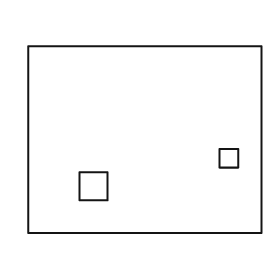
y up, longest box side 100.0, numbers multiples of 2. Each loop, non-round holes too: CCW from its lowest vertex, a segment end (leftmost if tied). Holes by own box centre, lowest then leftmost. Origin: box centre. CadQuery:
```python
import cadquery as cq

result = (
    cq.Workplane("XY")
    .moveTo(-50.0, -40.0)
    .lineTo(50.0, -40.0)
    .lineTo(50.0, 40.0)
    .lineTo(-50.0, 40.0)
    .close()
    .moveTo(-28.0, -26.0)
    .lineTo(-16.0, -26.0)
    .lineTo(-16.0, -14.0)
    .lineTo(-28.0, -14.0)
    .close()
    .moveTo(32.0, -12.0)
    .lineTo(40.0, -12.0)
    .lineTo(40.0, -4.0)
    .lineTo(32.0, -4.0)
    .close()
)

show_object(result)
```